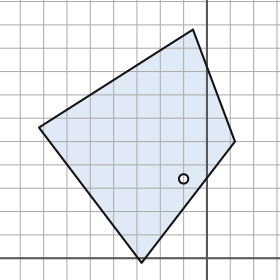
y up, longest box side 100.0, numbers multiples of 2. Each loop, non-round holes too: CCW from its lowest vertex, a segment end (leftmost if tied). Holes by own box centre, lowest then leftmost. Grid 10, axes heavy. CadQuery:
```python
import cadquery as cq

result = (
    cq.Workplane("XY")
    .moveTo(-28.0, -2.0)
    .lineTo(12.0, 50.0)
    .lineTo(-6.0, 98.0)
    .lineTo(-72.0, 56.0)
    .close()
    .moveTo(-10.0, 34.0)
    .circle(2.0)
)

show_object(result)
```